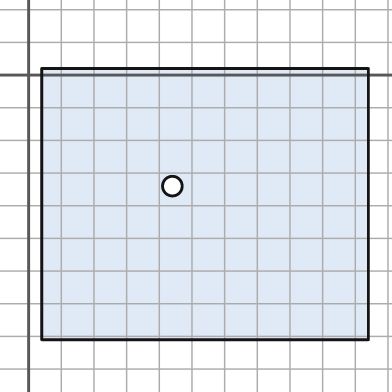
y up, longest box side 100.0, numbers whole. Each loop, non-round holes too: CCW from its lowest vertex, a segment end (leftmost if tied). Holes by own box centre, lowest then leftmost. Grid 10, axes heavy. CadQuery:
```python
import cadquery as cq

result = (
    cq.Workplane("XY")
    .moveTo(4.0, -81.0)
    .lineTo(104.0, -81.0)
    .lineTo(104.0, 2.0)
    .lineTo(4.0, 2.0)
    .close()
    .moveTo(44.0, -34.0)
    .circle(3.0)
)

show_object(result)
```